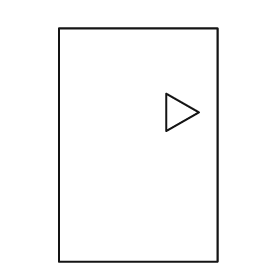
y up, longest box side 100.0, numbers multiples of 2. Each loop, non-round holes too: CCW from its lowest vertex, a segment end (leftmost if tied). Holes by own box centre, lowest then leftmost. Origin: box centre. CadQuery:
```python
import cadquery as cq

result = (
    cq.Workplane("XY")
    .moveTo(-34.0, -50.0)
    .lineTo(34.0, -50.0)
    .lineTo(34.0, 50.0)
    .lineTo(-34.0, 50.0)
    .close()
    .moveTo(12.0, 6.0)
    .lineTo(26.0, 14.0)
    .lineTo(12.0, 22.0)
    .close()
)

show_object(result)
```